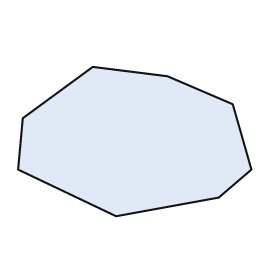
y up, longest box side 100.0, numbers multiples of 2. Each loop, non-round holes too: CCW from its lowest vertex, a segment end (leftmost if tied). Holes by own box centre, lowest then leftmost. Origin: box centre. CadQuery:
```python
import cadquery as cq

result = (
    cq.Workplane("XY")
    .moveTo(-8.0, -32.0)
    .lineTo(36.0, -24.0)
    .lineTo(50.0, -12.0)
    .lineTo(42.0, 16.0)
    .lineTo(14.0, 28.0)
    .lineTo(-18.0, 32.0)
    .lineTo(-48.0, 10.0)
    .lineTo(-50.0, -12.0)
    .close()
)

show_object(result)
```